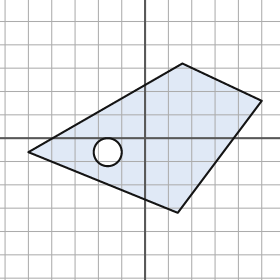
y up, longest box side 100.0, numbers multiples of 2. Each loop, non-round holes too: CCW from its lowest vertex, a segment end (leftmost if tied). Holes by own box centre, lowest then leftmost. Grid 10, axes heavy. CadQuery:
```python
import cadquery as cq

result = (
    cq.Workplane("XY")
    .moveTo(14.0, -32.0)
    .lineTo(50.0, 16.0)
    .lineTo(16.0, 32.0)
    .lineTo(-50.0, -6.0)
    .close()
    .moveTo(-16.0, -6.0)
    .circle(6.0)
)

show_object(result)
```